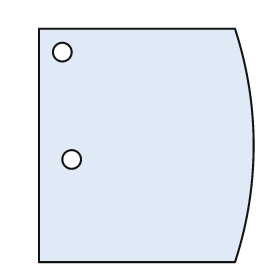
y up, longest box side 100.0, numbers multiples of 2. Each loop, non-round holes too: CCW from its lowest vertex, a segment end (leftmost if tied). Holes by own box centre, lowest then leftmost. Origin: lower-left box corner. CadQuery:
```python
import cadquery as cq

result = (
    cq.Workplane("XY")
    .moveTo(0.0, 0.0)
    .lineTo(84.0, 0.0)
    .threePointArc((92.0, 50.0), (84.0, 100.0))
    .lineTo(0.0, 100.0)
    .close()
    .moveTo(14.0, 44.0)
    .circle(4.0)
    .moveTo(10.0, 90.0)
    .circle(4.0)
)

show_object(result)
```